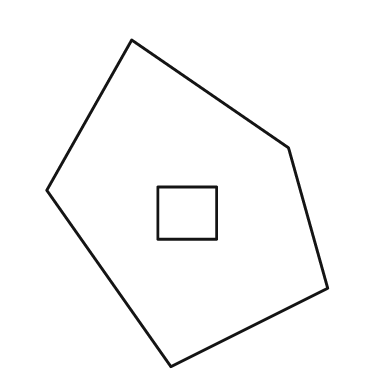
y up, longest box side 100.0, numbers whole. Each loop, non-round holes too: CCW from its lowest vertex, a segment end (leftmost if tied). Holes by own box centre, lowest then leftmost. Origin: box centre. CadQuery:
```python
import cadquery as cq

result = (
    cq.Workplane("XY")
    .moveTo(-5.0, -50.0)
    .lineTo(43.0, -26.0)
    .lineTo(31.0, 17.0)
    .lineTo(-17.0, 50.0)
    .lineTo(-43.0, 4.0)
    .close()
    .moveTo(-9.0, -11.0)
    .lineTo(9.0, -11.0)
    .lineTo(9.0, 5.0)
    .lineTo(-9.0, 5.0)
    .close()
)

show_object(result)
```